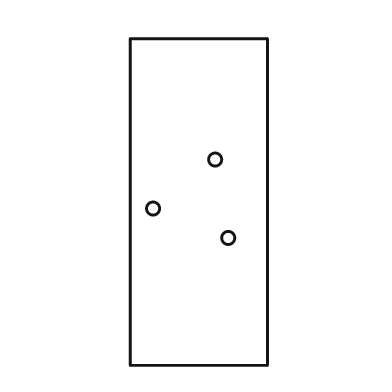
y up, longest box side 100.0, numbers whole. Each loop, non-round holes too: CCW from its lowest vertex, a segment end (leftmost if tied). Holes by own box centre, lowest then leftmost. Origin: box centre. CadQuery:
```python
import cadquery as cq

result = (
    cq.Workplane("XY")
    .moveTo(-21.0, -50.0)
    .lineTo(21.0, -50.0)
    .lineTo(21.0, 50.0)
    .lineTo(-21.0, 50.0)
    .close()
    .moveTo(9.0, -11.0)
    .circle(2.0)
    .moveTo(-14.0, -2.0)
    .circle(2.0)
    .moveTo(5.0, 13.0)
    .circle(2.0)
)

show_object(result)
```